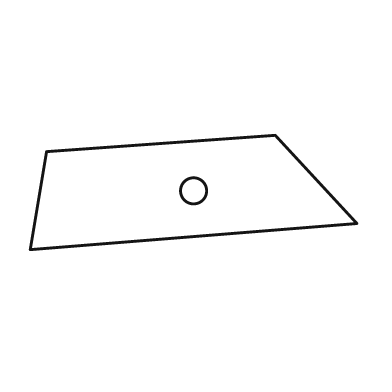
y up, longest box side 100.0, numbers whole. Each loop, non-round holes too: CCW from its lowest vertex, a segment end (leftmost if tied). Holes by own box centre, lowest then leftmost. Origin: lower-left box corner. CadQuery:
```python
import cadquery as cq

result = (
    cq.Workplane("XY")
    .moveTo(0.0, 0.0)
    .lineTo(100.0, 8.0)
    .lineTo(75.0, 35.0)
    .lineTo(5.0, 30.0)
    .close()
    .moveTo(50.0, 18.0)
    .circle(4.0)
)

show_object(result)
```